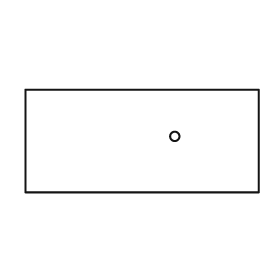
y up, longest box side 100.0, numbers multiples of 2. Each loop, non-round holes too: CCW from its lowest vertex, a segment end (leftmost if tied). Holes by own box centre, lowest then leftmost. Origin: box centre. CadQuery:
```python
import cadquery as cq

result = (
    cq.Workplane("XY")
    .moveTo(-50.0, -22.0)
    .lineTo(50.0, -22.0)
    .lineTo(50.0, 22.0)
    .lineTo(-50.0, 22.0)
    .close()
    .moveTo(14.0, 2.0)
    .circle(2.0)
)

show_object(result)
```